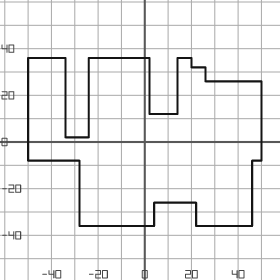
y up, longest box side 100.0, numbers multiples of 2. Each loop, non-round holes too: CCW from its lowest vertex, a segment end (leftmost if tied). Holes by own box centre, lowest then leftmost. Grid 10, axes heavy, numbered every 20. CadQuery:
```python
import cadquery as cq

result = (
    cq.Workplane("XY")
    .moveTo(-28.0, -36.0)
    .lineTo(4.0, -36.0)
    .lineTo(4.0, -26.0)
    .lineTo(22.0, -26.0)
    .lineTo(22.0, -36.0)
    .lineTo(46.0, -36.0)
    .lineTo(46.0, -8.0)
    .lineTo(50.0, -8.0)
    .lineTo(50.0, 26.0)
    .lineTo(26.0, 26.0)
    .lineTo(26.0, 32.0)
    .lineTo(20.0, 32.0)
    .lineTo(20.0, 36.0)
    .lineTo(14.0, 36.0)
    .lineTo(14.0, 12.0)
    .lineTo(2.0, 12.0)
    .lineTo(2.0, 36.0)
    .lineTo(-24.0, 36.0)
    .lineTo(-24.0, 2.0)
    .lineTo(-34.0, 2.0)
    .lineTo(-34.0, 36.0)
    .lineTo(-50.0, 36.0)
    .lineTo(-50.0, -8.0)
    .lineTo(-28.0, -8.0)
    .close()
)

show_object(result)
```